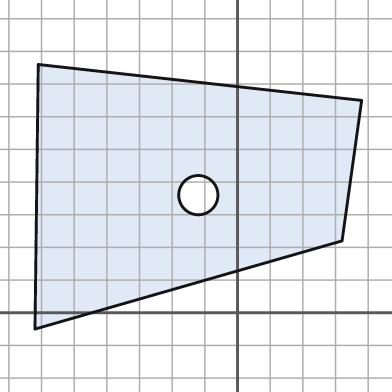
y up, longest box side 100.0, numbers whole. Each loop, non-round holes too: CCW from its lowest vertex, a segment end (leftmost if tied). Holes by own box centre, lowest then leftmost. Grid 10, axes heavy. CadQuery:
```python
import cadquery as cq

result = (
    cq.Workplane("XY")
    .moveTo(-62.0, -5.0)
    .lineTo(32.0, 22.0)
    .lineTo(38.0, 65.0)
    .lineTo(-61.0, 76.0)
    .close()
    .moveTo(-12.0, 36.0)
    .circle(6.0)
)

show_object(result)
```